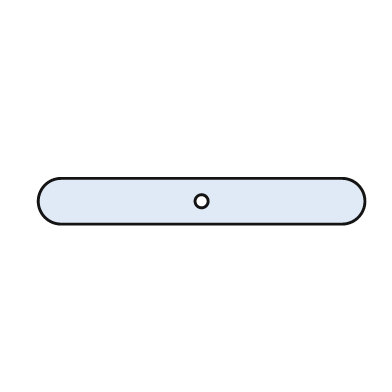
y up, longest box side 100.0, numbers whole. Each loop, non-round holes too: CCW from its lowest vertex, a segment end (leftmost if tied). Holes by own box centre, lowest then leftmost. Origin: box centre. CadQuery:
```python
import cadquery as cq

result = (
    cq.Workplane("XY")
    .moveTo(-43.0, -7.0)
    .lineTo(43.0, -7.0)
    .threePointArc((50.0, 0.0), (43.0, 7.0))
    .lineTo(-43.0, 7.0)
    .threePointArc((-50.0, 0.0), (-43.0, -7.0))
    .close()
    .moveTo(0.0, 0.0)
    .circle(2.0)
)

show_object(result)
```